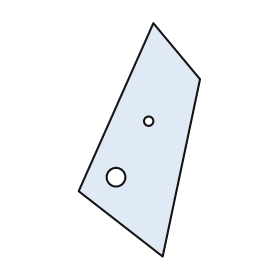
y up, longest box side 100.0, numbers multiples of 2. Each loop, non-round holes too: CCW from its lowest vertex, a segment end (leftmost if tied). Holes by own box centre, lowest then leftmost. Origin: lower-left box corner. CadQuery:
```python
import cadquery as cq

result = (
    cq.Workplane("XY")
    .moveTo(36.0, 0.0)
    .lineTo(52.0, 76.0)
    .lineTo(32.0, 100.0)
    .lineTo(0.0, 28.0)
    .close()
    .moveTo(16.0, 34.0)
    .circle(4.0)
    .moveTo(30.0, 58.0)
    .circle(2.0)
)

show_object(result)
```